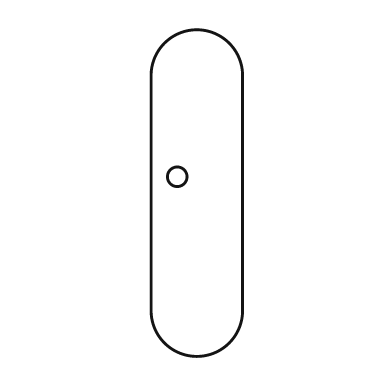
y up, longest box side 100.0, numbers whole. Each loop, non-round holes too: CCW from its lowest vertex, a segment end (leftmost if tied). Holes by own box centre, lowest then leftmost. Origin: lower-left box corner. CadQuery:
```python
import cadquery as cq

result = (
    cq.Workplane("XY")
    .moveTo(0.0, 14.0)
    .threePointArc((14.0, 0.0), (28.0, 14.0))
    .lineTo(28.0, 86.0)
    .threePointArc((14.0, 100.0), (0.0, 86.0))
    .close()
    .moveTo(8.0, 55.0)
    .circle(3.0)
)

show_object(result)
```